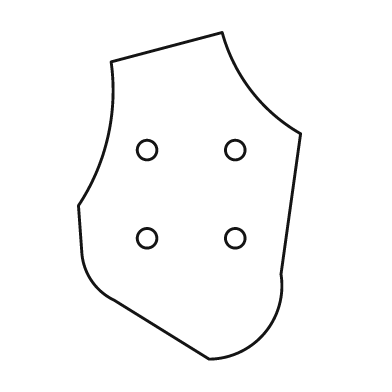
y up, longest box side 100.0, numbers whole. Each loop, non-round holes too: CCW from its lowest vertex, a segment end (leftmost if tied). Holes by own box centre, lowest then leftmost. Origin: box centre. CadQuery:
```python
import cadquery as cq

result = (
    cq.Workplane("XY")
    .moveTo(6.0, -50.0)
    .threePointArc((23.0, -42.0), (28.0, -24.0))
    .lineTo(34.0, 19.0)
    .threePointArc((19.0, 32.0), (10.0, 50.0))
    .lineTo(-24.0, 41.0)
    .threePointArc((-25.0, 18.0), (-34.0, -3.0))
    .lineTo(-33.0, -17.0)
    .threePointArc((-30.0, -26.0), (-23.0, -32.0))
    .close()
    .moveTo(-13.0, -13.0)
    .circle(3.0)
    .moveTo(14.0, -13.0)
    .circle(3.0)
    .moveTo(-13.0, 14.0)
    .circle(3.0)
    .moveTo(14.0, 14.0)
    .circle(3.0)
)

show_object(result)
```